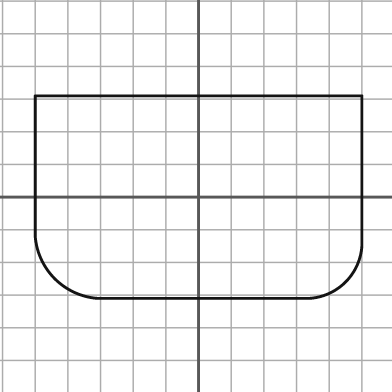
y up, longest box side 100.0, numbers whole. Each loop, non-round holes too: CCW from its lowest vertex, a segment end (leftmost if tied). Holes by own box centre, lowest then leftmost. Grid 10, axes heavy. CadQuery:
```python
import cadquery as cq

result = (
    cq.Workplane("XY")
    .moveTo(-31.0, -31.0)
    .lineTo(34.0, -31.0)
    .threePointArc((45.0, -26.0), (50.0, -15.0))
    .lineTo(50.0, 31.0)
    .lineTo(-50.0, 31.0)
    .lineTo(-50.0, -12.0)
    .threePointArc((-44.0, -25.0), (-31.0, -31.0))
    .close()
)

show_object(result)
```